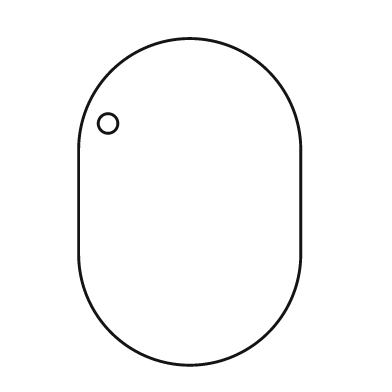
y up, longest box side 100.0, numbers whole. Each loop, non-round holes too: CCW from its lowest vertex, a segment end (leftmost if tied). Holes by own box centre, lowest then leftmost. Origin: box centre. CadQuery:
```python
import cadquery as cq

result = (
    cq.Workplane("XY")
    .moveTo(-34.0, -16.0)
    .threePointArc((0.0, -50.0), (34.0, -16.0))
    .lineTo(34.0, 16.0)
    .threePointArc((0.0, 50.0), (-34.0, 16.0))
    .close()
    .moveTo(-25.0, 24.0)
    .circle(3.0)
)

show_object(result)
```